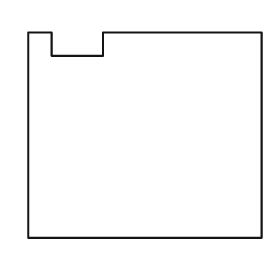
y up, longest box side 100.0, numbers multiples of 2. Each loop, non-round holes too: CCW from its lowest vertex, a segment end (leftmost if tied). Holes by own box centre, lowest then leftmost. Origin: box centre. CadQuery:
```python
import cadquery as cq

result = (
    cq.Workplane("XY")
    .moveTo(-50.0, -44.0)
    .lineTo(50.0, -44.0)
    .lineTo(50.0, 44.0)
    .lineTo(-18.0, 44.0)
    .lineTo(-18.0, 34.0)
    .lineTo(-40.0, 34.0)
    .lineTo(-40.0, 44.0)
    .lineTo(-50.0, 44.0)
    .close()
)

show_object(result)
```